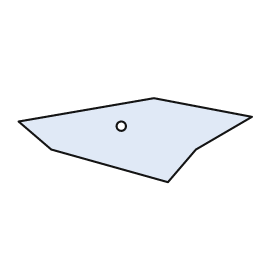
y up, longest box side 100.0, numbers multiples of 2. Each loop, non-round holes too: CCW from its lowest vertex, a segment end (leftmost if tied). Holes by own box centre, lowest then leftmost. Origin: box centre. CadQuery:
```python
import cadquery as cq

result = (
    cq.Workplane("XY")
    .moveTo(14.0, -18.0)
    .lineTo(26.0, -4.0)
    .lineTo(50.0, 10.0)
    .lineTo(8.0, 18.0)
    .lineTo(-50.0, 8.0)
    .lineTo(-36.0, -4.0)
    .close()
    .moveTo(-6.0, 6.0)
    .circle(2.0)
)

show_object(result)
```